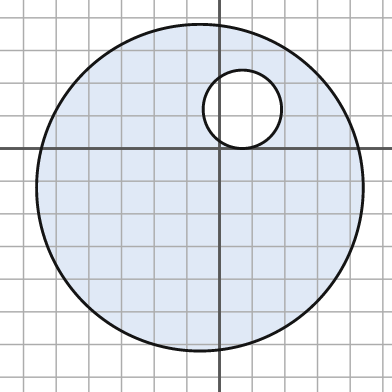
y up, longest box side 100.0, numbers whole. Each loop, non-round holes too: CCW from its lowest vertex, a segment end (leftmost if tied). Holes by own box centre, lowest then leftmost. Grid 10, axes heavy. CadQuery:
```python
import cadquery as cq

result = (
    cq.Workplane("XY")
    .moveTo(-6.0, -12.0)
    .circle(50.0)
    .moveTo(7.0, 12.0)
    .circle(12.0)
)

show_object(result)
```